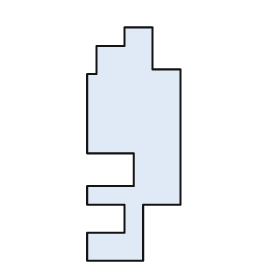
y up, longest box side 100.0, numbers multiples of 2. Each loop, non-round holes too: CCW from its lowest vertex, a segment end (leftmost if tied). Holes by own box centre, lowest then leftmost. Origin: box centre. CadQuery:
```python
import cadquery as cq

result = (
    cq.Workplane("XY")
    .moveTo(-20.0, -50.0)
    .lineTo(4.0, -50.0)
    .lineTo(4.0, -26.0)
    .lineTo(20.0, -26.0)
    .lineTo(20.0, 32.0)
    .lineTo(8.0, 32.0)
    .lineTo(8.0, 50.0)
    .lineTo(-4.0, 50.0)
    .lineTo(-4.0, 42.0)
    .lineTo(-16.0, 42.0)
    .lineTo(-16.0, 30.0)
    .lineTo(-20.0, 30.0)
    .lineTo(-20.0, -4.0)
    .lineTo(0.0, -4.0)
    .lineTo(0.0, -18.0)
    .lineTo(-20.0, -18.0)
    .lineTo(-20.0, -26.0)
    .lineTo(-4.0, -26.0)
    .lineTo(-4.0, -38.0)
    .lineTo(-20.0, -38.0)
    .close()
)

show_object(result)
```